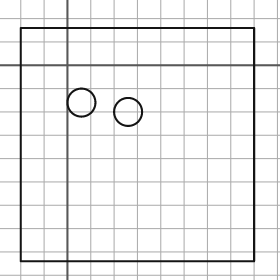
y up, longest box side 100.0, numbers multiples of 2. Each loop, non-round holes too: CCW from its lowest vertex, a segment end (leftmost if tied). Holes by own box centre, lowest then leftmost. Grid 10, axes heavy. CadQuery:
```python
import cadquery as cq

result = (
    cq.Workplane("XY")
    .moveTo(-20.0, -84.0)
    .lineTo(80.0, -84.0)
    .lineTo(80.0, 16.0)
    .lineTo(-20.0, 16.0)
    .close()
    .moveTo(26.0, -20.0)
    .circle(6.0)
    .moveTo(6.0, -16.0)
    .circle(6.0)
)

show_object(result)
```